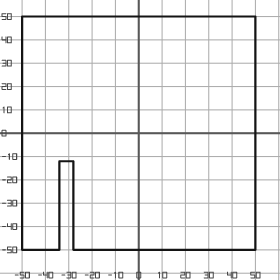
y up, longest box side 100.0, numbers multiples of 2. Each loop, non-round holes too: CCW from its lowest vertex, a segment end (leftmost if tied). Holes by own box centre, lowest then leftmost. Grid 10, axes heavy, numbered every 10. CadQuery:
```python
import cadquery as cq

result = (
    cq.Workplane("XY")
    .moveTo(-50.0, -50.0)
    .lineTo(-34.0, -50.0)
    .lineTo(-34.0, -12.0)
    .lineTo(-28.0, -12.0)
    .lineTo(-28.0, -50.0)
    .lineTo(50.0, -50.0)
    .lineTo(50.0, 50.0)
    .lineTo(-50.0, 50.0)
    .close()
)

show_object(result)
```